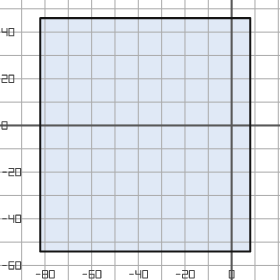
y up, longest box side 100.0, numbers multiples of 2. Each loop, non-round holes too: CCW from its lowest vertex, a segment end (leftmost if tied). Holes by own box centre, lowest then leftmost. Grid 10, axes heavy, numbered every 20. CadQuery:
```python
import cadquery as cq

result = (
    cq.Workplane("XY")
    .moveTo(-82.0, -54.0)
    .lineTo(8.0, -54.0)
    .lineTo(8.0, 46.0)
    .lineTo(-82.0, 46.0)
    .close()
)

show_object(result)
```